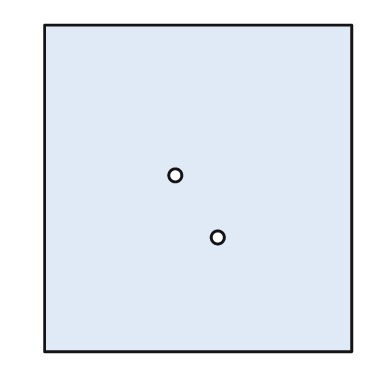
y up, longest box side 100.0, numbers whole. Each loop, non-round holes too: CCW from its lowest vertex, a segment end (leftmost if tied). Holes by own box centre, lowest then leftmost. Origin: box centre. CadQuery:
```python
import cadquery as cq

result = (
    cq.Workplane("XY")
    .moveTo(-47.0, -50.0)
    .lineTo(47.0, -50.0)
    .lineTo(47.0, 50.0)
    .lineTo(-47.0, 50.0)
    .close()
    .moveTo(6.0, -15.0)
    .circle(2.0)
    .moveTo(-7.0, 4.0)
    .circle(2.0)
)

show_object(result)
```